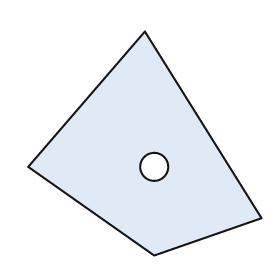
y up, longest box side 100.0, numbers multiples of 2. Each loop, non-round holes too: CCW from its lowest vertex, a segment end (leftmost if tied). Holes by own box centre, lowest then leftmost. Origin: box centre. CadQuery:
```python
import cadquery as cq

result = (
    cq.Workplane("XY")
    .moveTo(4.0, -48.0)
    .lineTo(50.0, -32.0)
    .lineTo(0.0, 48.0)
    .lineTo(-50.0, -10.0)
    .close()
    .moveTo(4.0, -10.0)
    .circle(6.0)
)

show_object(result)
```